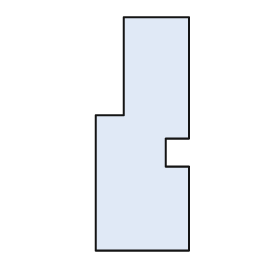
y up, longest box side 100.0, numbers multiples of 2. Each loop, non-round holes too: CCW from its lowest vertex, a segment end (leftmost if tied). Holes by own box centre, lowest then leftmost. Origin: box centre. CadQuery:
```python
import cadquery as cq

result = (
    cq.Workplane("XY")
    .moveTo(-20.0, -50.0)
    .lineTo(20.0, -50.0)
    .lineTo(20.0, -14.0)
    .lineTo(10.0, -14.0)
    .lineTo(10.0, -2.0)
    .lineTo(20.0, -2.0)
    .lineTo(20.0, 50.0)
    .lineTo(-8.0, 50.0)
    .lineTo(-8.0, 8.0)
    .lineTo(-20.0, 8.0)
    .close()
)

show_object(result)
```